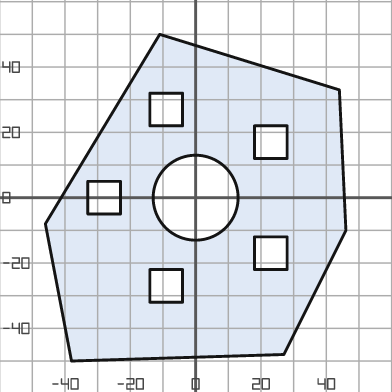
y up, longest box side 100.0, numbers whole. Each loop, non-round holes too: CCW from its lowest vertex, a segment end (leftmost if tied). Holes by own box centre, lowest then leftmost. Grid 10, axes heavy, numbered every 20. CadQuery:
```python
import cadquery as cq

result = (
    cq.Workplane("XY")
    .moveTo(-38.0, -50.0)
    .lineTo(27.0, -48.0)
    .lineTo(46.0, -10.0)
    .lineTo(44.0, 33.0)
    .lineTo(-11.0, 50.0)
    .lineTo(-46.0, -8.0)
    .close()
    .moveTo(-14.0, -32.0)
    .lineTo(-4.0, -32.0)
    .lineTo(-4.0, -22.0)
    .lineTo(-14.0, -22.0)
    .close()
    .moveTo(18.0, -22.0)
    .lineTo(28.0, -22.0)
    .lineTo(28.0, -12.0)
    .lineTo(18.0, -12.0)
    .close()
    .moveTo(-33.0, -5.0)
    .lineTo(-23.0, -5.0)
    .lineTo(-23.0, 5.0)
    .lineTo(-33.0, 5.0)
    .close()
    .moveTo(0.0, 0.0)
    .circle(13.0)
    .moveTo(18.0, 12.0)
    .lineTo(28.0, 12.0)
    .lineTo(28.0, 22.0)
    .lineTo(18.0, 22.0)
    .close()
    .moveTo(-14.0, 22.0)
    .lineTo(-4.0, 22.0)
    .lineTo(-4.0, 32.0)
    .lineTo(-14.0, 32.0)
    .close()
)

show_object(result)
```